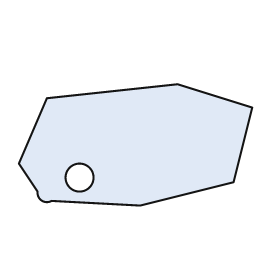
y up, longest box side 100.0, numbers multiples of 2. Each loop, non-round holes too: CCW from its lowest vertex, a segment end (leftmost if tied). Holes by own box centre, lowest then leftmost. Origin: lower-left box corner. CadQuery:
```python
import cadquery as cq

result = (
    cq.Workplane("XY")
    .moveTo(52.0, 0.0)
    .lineTo(92.0, 10.0)
    .lineTo(100.0, 42.0)
    .lineTo(68.0, 52.0)
    .lineTo(12.0, 46.0)
    .lineTo(0.0, 18.0)
    .lineTo(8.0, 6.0)
    .threePointArc((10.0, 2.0), (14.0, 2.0))
    .close()
    .moveTo(26.0, 12.0)
    .circle(6.0)
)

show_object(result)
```